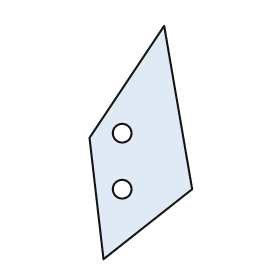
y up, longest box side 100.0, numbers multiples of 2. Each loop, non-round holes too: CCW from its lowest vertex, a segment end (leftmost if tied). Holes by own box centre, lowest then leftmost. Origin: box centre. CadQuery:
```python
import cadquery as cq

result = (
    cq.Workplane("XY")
    .moveTo(-16.0, -50.0)
    .lineTo(22.0, -20.0)
    .lineTo(10.0, 50.0)
    .lineTo(-22.0, 2.0)
    .close()
    .moveTo(-8.0, -20.0)
    .circle(4.0)
    .moveTo(-8.0, 4.0)
    .circle(4.0)
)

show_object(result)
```